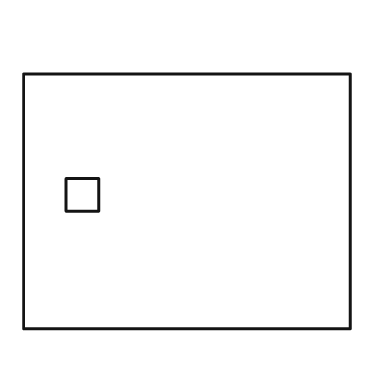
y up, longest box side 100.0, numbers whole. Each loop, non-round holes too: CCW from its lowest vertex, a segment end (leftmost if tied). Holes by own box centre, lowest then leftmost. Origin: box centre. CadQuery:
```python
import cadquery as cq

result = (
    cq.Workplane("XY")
    .moveTo(-50.0, -39.0)
    .lineTo(50.0, -39.0)
    .lineTo(50.0, 39.0)
    .lineTo(-50.0, 39.0)
    .close()
    .moveTo(-37.0, -3.0)
    .lineTo(-27.0, -3.0)
    .lineTo(-27.0, 7.0)
    .lineTo(-37.0, 7.0)
    .close()
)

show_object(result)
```